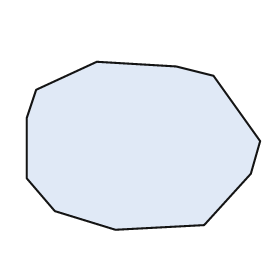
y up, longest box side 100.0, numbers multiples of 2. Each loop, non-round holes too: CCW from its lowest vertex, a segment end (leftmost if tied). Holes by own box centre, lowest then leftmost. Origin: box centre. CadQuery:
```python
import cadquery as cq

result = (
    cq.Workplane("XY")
    .moveTo(-12.0, -36.0)
    .lineTo(26.0, -34.0)
    .lineTo(46.0, -12.0)
    .lineTo(50.0, 2.0)
    .lineTo(30.0, 30.0)
    .lineTo(14.0, 34.0)
    .lineTo(-20.0, 36.0)
    .lineTo(-46.0, 24.0)
    .lineTo(-50.0, 12.0)
    .lineTo(-50.0, -14.0)
    .lineTo(-38.0, -28.0)
    .close()
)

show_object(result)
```